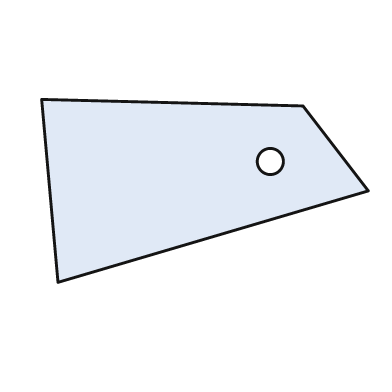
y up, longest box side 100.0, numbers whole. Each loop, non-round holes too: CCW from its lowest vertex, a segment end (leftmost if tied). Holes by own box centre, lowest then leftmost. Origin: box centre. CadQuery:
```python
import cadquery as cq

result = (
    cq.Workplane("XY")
    .moveTo(-45.0, -28.0)
    .lineTo(50.0, 0.0)
    .lineTo(30.0, 26.0)
    .lineTo(-50.0, 28.0)
    .close()
    .moveTo(20.0, 9.0)
    .circle(4.0)
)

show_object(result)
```